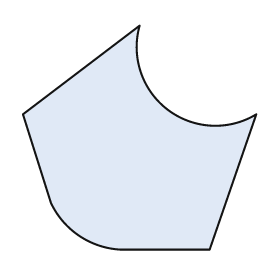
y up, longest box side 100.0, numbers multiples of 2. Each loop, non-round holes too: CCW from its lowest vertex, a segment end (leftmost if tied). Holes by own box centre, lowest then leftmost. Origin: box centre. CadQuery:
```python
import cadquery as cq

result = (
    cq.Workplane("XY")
    .moveTo(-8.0, -48.0)
    .lineTo(30.0, -48.0)
    .lineTo(50.0, 10.0)
    .threePointArc((12.0, 12.0), (0.0, 48.0))
    .lineTo(-50.0, 10.0)
    .lineTo(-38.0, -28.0)
    .threePointArc((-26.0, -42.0), (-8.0, -48.0))
    .close()
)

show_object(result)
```